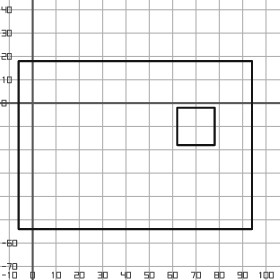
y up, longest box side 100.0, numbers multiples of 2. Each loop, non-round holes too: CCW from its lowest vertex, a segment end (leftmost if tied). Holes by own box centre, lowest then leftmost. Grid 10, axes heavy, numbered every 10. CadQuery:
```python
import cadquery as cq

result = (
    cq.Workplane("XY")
    .moveTo(-6.0, -54.0)
    .lineTo(94.0, -54.0)
    .lineTo(94.0, 18.0)
    .lineTo(-6.0, 18.0)
    .close()
    .moveTo(62.0, -18.0)
    .lineTo(78.0, -18.0)
    .lineTo(78.0, -2.0)
    .lineTo(62.0, -2.0)
    .close()
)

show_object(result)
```